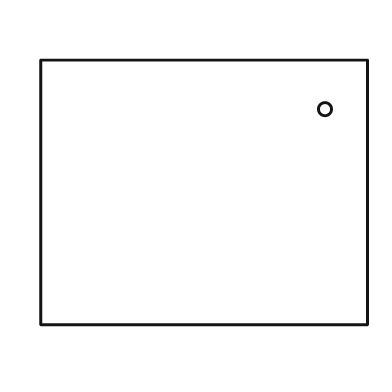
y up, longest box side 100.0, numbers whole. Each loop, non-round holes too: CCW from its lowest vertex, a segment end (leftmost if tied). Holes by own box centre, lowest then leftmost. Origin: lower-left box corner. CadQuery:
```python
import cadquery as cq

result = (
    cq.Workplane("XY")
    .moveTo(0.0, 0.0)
    .lineTo(100.0, 0.0)
    .lineTo(100.0, 81.0)
    .lineTo(0.0, 81.0)
    .close()
    .moveTo(87.0, 66.0)
    .circle(2.0)
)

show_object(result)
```